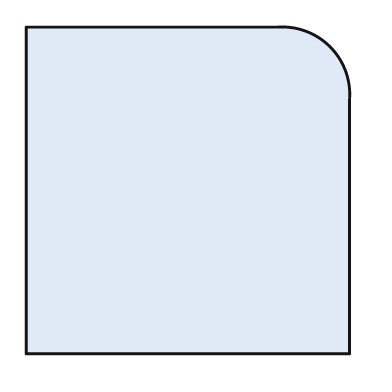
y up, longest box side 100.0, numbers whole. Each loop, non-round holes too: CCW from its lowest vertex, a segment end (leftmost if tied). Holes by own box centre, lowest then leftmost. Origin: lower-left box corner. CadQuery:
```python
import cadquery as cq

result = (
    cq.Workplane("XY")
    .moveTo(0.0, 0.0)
    .lineTo(99.0, 0.0)
    .lineTo(99.0, 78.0)
    .threePointArc((93.0, 94.0), (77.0, 100.0))
    .lineTo(0.0, 100.0)
    .close()
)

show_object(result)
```